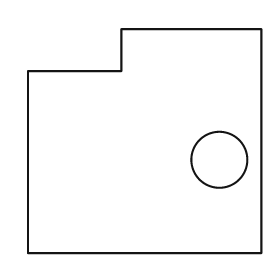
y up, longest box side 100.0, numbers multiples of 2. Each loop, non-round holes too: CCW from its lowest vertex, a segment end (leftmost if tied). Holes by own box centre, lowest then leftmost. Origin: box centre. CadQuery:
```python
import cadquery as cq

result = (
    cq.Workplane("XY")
    .moveTo(-50.0, -48.0)
    .lineTo(50.0, -48.0)
    .lineTo(50.0, 48.0)
    .lineTo(-10.0, 48.0)
    .lineTo(-10.0, 30.0)
    .lineTo(-50.0, 30.0)
    .close()
    .moveTo(32.0, -8.0)
    .circle(12.0)
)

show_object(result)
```